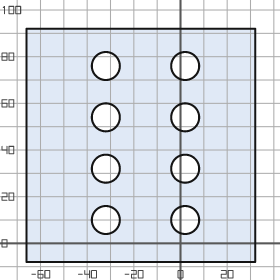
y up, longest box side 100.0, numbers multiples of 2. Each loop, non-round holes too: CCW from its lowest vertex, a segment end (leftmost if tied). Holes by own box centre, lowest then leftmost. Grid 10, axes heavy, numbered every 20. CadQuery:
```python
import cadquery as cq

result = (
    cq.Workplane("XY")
    .moveTo(-66.0, -8.0)
    .lineTo(32.0, -8.0)
    .lineTo(32.0, 92.0)
    .lineTo(-66.0, 92.0)
    .close()
    .moveTo(-32.0, 10.0)
    .circle(6.0)
    .moveTo(2.0, 10.0)
    .circle(6.0)
    .moveTo(-32.0, 32.0)
    .circle(6.0)
    .moveTo(2.0, 32.0)
    .circle(6.0)
    .moveTo(-32.0, 54.0)
    .circle(6.0)
    .moveTo(2.0, 54.0)
    .circle(6.0)
    .moveTo(-32.0, 76.0)
    .circle(6.0)
    .moveTo(2.0, 76.0)
    .circle(6.0)
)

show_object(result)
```